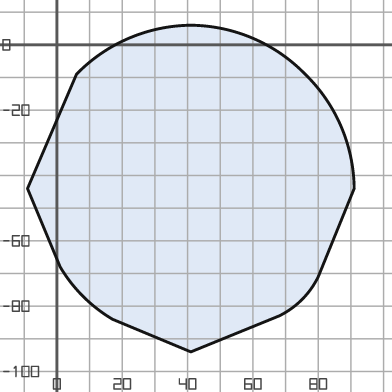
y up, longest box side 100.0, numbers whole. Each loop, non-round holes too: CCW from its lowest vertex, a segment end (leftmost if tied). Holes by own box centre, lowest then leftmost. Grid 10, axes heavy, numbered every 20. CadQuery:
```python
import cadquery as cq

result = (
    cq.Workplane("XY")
    .moveTo(41.0, -94.0)
    .lineTo(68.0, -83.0)
    .threePointArc((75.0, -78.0), (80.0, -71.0))
    .lineTo(91.0, -44.0)
    .threePointArc((87.0, -25.0), (76.0, -9.0))
    .threePointArc((60.0, 2.0), (41.0, 6.0))
    .threePointArc((22.0, 2.0), (6.0, -9.0))
    .lineTo(-9.0, -44.0)
    .lineTo(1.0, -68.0)
    .threePointArc((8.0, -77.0), (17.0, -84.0))
    .close()
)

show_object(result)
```